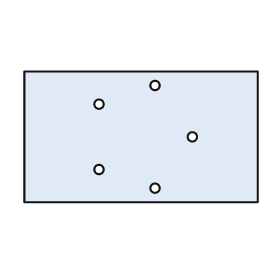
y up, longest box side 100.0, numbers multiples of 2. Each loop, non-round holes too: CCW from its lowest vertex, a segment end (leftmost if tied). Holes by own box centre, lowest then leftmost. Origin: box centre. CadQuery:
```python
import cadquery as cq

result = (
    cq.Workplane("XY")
    .moveTo(-50.0, -28.0)
    .lineTo(50.0, -28.0)
    .lineTo(50.0, 28.0)
    .lineTo(-50.0, 28.0)
    .close()
    .moveTo(6.0, -22.0)
    .circle(2.0)
    .moveTo(-18.0, -14.0)
    .circle(2.0)
    .moveTo(22.0, 0.0)
    .circle(2.0)
    .moveTo(-18.0, 14.0)
    .circle(2.0)
    .moveTo(6.0, 22.0)
    .circle(2.0)
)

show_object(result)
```